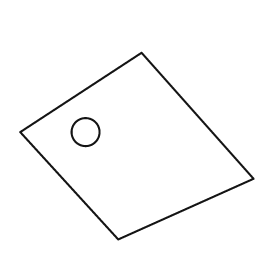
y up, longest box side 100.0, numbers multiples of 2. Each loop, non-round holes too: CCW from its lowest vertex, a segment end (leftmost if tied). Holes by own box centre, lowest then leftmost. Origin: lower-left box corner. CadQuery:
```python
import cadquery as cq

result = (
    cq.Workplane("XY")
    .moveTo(42.0, 0.0)
    .lineTo(100.0, 26.0)
    .lineTo(52.0, 80.0)
    .lineTo(0.0, 46.0)
    .close()
    .moveTo(28.0, 46.0)
    .circle(6.0)
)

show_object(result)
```